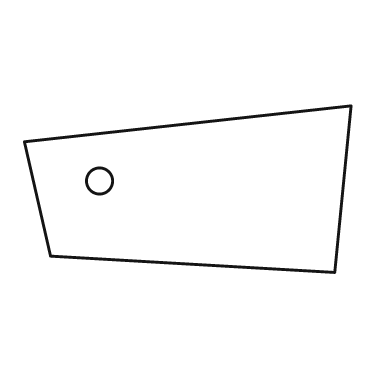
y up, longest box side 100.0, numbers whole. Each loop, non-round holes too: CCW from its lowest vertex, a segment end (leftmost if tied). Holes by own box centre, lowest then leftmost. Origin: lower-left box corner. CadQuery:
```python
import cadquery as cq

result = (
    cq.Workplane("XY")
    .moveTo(95.0, 0.0)
    .lineTo(100.0, 51.0)
    .lineTo(0.0, 40.0)
    .lineTo(8.0, 5.0)
    .close()
    .moveTo(23.0, 28.0)
    .circle(4.0)
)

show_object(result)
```